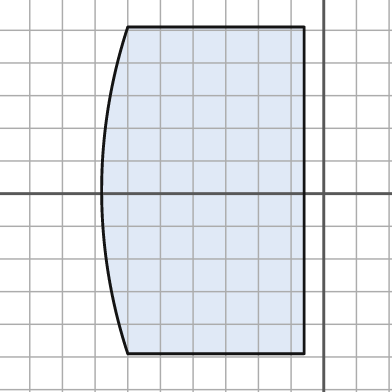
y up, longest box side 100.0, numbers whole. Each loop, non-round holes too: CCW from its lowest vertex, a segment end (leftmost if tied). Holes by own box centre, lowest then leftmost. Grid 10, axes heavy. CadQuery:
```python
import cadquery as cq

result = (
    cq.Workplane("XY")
    .moveTo(-60.0, -49.0)
    .lineTo(-6.0, -49.0)
    .lineTo(-6.0, 51.0)
    .lineTo(-60.0, 51.0)
    .threePointArc((-68.0, 1.0), (-60.0, -49.0))
    .close()
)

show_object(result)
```